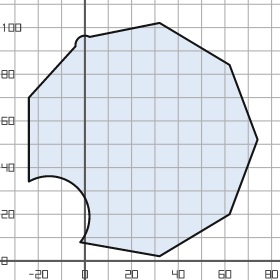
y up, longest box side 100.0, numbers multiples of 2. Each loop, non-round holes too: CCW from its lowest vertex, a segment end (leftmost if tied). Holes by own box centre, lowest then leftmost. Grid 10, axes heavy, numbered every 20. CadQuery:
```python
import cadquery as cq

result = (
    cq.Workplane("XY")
    .moveTo(32.0, 2.0)
    .lineTo(62.0, 20.0)
    .lineTo(74.0, 52.0)
    .lineTo(62.0, 84.0)
    .lineTo(32.0, 102.0)
    .lineTo(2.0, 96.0)
    .threePointArc((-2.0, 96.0), (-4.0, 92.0))
    .lineTo(-24.0, 70.0)
    .lineTo(-24.0, 34.0)
    .threePointArc((-2.0, 30.0), (-2.0, 8.0))
    .close()
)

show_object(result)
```